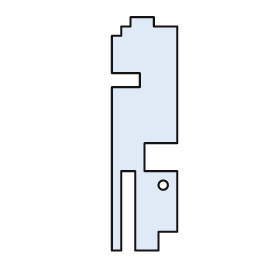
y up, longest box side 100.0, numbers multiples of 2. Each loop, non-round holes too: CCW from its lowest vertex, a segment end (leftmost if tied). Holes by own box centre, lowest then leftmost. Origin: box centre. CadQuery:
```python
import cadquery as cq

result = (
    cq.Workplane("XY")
    .moveTo(-14.0, -50.0)
    .lineTo(-10.0, -50.0)
    .lineTo(-10.0, -16.0)
    .lineTo(-4.0, -16.0)
    .lineTo(-4.0, -50.0)
    .lineTo(6.0, -50.0)
    .lineTo(6.0, -42.0)
    .lineTo(14.0, -42.0)
    .lineTo(14.0, -16.0)
    .lineTo(0.0, -16.0)
    .lineTo(0.0, -4.0)
    .lineTo(14.0, -4.0)
    .lineTo(14.0, 46.0)
    .lineTo(4.0, 46.0)
    .lineTo(4.0, 50.0)
    .lineTo(-6.0, 50.0)
    .lineTo(-6.0, 46.0)
    .lineTo(-10.0, 46.0)
    .lineTo(-10.0, 42.0)
    .lineTo(-14.0, 42.0)
    .lineTo(-14.0, 26.0)
    .lineTo(-2.0, 26.0)
    .lineTo(-2.0, 20.0)
    .lineTo(-14.0, 20.0)
    .close()
    .moveTo(8.0, -22.0)
    .circle(2.0)
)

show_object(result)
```